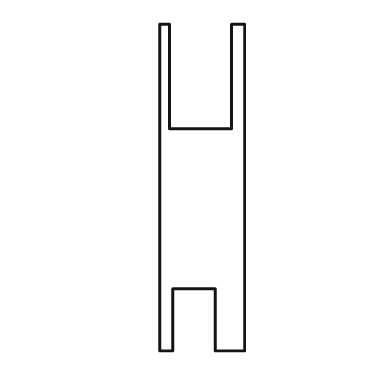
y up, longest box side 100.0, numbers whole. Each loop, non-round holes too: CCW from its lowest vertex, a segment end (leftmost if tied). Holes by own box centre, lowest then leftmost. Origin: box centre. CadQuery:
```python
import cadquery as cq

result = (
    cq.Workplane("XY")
    .moveTo(-13.0, -50.0)
    .lineTo(-9.0, -50.0)
    .lineTo(-9.0, -31.0)
    .lineTo(4.0, -31.0)
    .lineTo(4.0, -50.0)
    .lineTo(13.0, -50.0)
    .lineTo(13.0, 50.0)
    .lineTo(9.0, 50.0)
    .lineTo(9.0, 18.0)
    .lineTo(-10.0, 18.0)
    .lineTo(-10.0, 50.0)
    .lineTo(-13.0, 50.0)
    .close()
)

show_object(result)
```